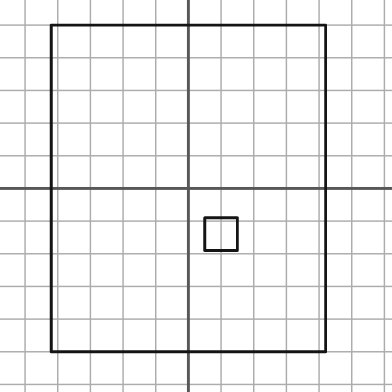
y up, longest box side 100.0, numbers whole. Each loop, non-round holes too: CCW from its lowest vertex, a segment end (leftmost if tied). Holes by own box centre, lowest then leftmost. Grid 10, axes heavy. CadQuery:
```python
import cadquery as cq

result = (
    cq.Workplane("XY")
    .moveTo(-42.0, -50.0)
    .lineTo(42.0, -50.0)
    .lineTo(42.0, 50.0)
    .lineTo(-42.0, 50.0)
    .close()
    .moveTo(5.0, -19.0)
    .lineTo(15.0, -19.0)
    .lineTo(15.0, -9.0)
    .lineTo(5.0, -9.0)
    .close()
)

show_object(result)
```